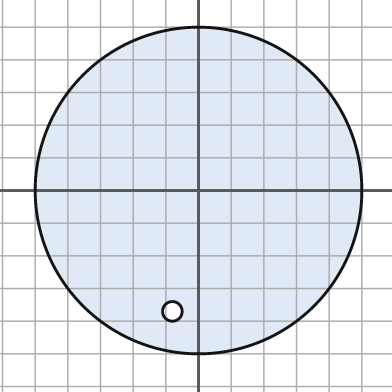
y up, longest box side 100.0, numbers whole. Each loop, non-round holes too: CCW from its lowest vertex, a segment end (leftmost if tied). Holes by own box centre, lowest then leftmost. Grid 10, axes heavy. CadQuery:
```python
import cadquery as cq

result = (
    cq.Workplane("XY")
    .moveTo(0.0, 0.0)
    .circle(50.0)
    .moveTo(-8.0, -37.0)
    .circle(3.0)
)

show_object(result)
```